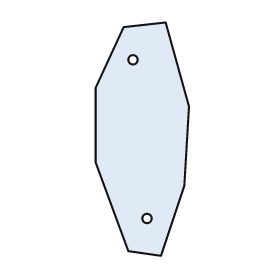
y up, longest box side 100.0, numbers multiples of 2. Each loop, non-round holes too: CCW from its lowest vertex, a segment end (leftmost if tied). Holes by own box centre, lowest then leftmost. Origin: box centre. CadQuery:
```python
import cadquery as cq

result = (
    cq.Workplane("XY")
    .moveTo(8.0, -50.0)
    .lineTo(18.0, -20.0)
    .lineTo(20.0, 14.0)
    .lineTo(10.0, 50.0)
    .lineTo(-8.0, 48.0)
    .lineTo(-20.0, 22.0)
    .lineTo(-20.0, -10.0)
    .lineTo(-6.0, -48.0)
    .close()
    .moveTo(2.0, -34.0)
    .circle(2.0)
    .moveTo(-4.0, 34.0)
    .circle(2.0)
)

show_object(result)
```